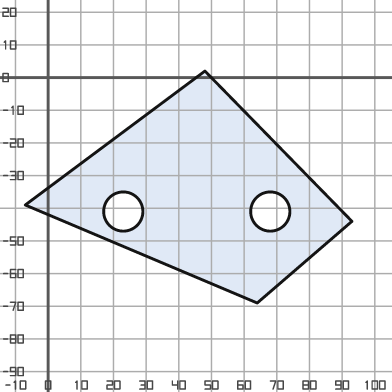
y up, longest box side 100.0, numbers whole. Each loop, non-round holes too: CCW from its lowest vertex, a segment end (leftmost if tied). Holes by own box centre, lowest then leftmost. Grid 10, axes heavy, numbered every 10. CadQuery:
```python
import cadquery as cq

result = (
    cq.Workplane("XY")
    .moveTo(64.0, -69.0)
    .lineTo(93.0, -44.0)
    .lineTo(48.0, 2.0)
    .lineTo(-7.0, -39.0)
    .close()
    .moveTo(23.0, -41.0)
    .circle(6.0)
    .moveTo(68.0, -41.0)
    .circle(6.0)
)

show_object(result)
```